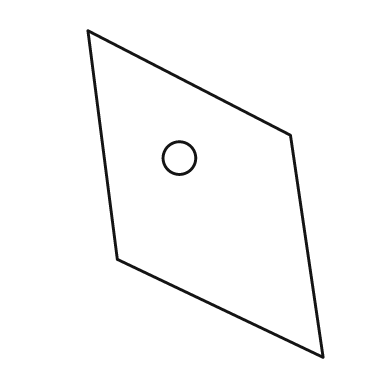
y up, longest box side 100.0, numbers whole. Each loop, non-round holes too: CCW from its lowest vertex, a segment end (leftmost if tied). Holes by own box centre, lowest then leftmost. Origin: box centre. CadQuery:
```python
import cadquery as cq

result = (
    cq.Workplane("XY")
    .moveTo(36.0, -50.0)
    .lineTo(26.0, 18.0)
    .lineTo(-36.0, 50.0)
    .lineTo(-27.0, -20.0)
    .close()
    .moveTo(-8.0, 11.0)
    .circle(5.0)
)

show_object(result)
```